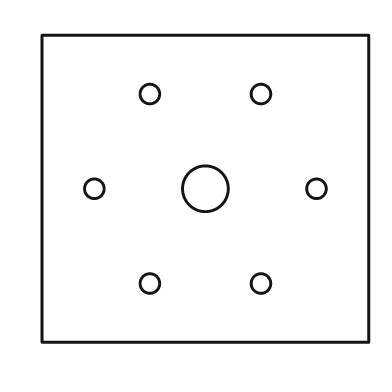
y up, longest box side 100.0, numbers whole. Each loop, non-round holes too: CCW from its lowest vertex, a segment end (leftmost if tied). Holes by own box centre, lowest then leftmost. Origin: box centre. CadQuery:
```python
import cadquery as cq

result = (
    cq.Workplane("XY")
    .moveTo(-50.0, -47.0)
    .lineTo(50.0, -47.0)
    .lineTo(50.0, 47.0)
    .lineTo(-50.0, 47.0)
    .close()
    .moveTo(-17.0, -29.0)
    .circle(3.0)
    .moveTo(17.0, -29.0)
    .circle(3.0)
    .moveTo(-34.0, 0.0)
    .circle(3.0)
    .moveTo(0.0, 0.0)
    .circle(7.0)
    .moveTo(34.0, 0.0)
    .circle(3.0)
    .moveTo(-17.0, 29.0)
    .circle(3.0)
    .moveTo(17.0, 29.0)
    .circle(3.0)
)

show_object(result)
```